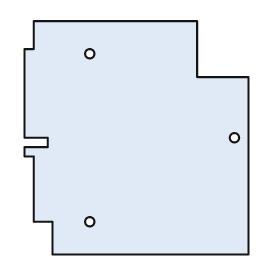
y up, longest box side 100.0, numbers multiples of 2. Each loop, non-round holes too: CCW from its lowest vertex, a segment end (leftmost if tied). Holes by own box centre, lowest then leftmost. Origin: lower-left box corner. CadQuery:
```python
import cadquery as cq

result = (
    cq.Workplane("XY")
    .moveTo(12.0, 0.0)
    .lineTo(96.0, 0.0)
    .lineTo(96.0, 76.0)
    .lineTo(74.0, 76.0)
    .lineTo(74.0, 100.0)
    .lineTo(4.0, 100.0)
    .lineTo(4.0, 88.0)
    .lineTo(0.0, 88.0)
    .lineTo(0.0, 50.0)
    .lineTo(10.0, 50.0)
    .lineTo(10.0, 46.0)
    .lineTo(0.0, 46.0)
    .lineTo(0.0, 42.0)
    .lineTo(4.0, 42.0)
    .lineTo(4.0, 14.0)
    .lineTo(12.0, 14.0)
    .close()
    .moveTo(28.0, 14.0)
    .circle(2.0)
    .moveTo(90.0, 50.0)
    .circle(2.0)
    .moveTo(28.0, 86.0)
    .circle(2.0)
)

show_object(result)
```